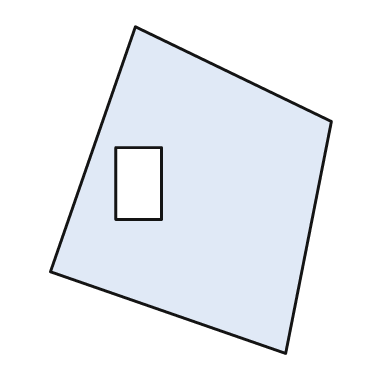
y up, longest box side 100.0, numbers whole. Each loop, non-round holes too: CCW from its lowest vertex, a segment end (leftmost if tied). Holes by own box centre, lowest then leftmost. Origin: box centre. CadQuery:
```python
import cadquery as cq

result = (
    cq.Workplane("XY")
    .moveTo(29.0, -50.0)
    .lineTo(43.0, 21.0)
    .lineTo(-17.0, 50.0)
    .lineTo(-43.0, -25.0)
    .close()
    .moveTo(-23.0, -9.0)
    .lineTo(-9.0, -9.0)
    .lineTo(-9.0, 13.0)
    .lineTo(-23.0, 13.0)
    .close()
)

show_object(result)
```